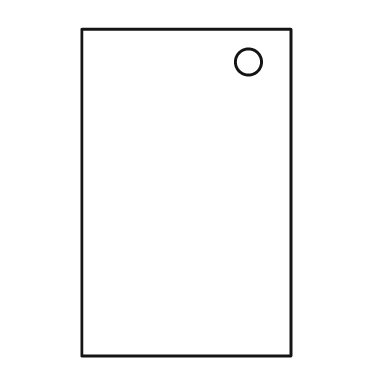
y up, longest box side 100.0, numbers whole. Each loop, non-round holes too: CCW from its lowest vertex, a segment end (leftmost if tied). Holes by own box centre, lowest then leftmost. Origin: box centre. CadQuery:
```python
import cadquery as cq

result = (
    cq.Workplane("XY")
    .moveTo(-32.0, -50.0)
    .lineTo(32.0, -50.0)
    .lineTo(32.0, 50.0)
    .lineTo(-32.0, 50.0)
    .close()
    .moveTo(19.0, 40.0)
    .circle(4.0)
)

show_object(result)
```